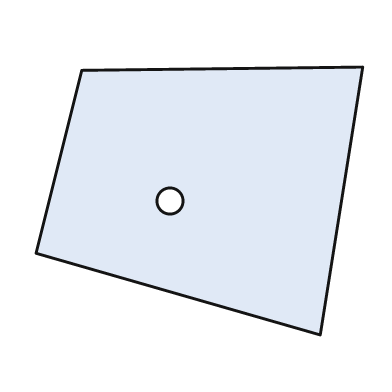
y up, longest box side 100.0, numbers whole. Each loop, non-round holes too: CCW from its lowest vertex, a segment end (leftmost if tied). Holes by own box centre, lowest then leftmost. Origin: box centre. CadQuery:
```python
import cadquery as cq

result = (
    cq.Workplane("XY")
    .moveTo(37.0, -41.0)
    .lineTo(50.0, 41.0)
    .lineTo(-36.0, 40.0)
    .lineTo(-50.0, -16.0)
    .close()
    .moveTo(-9.0, 0.0)
    .circle(4.0)
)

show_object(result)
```